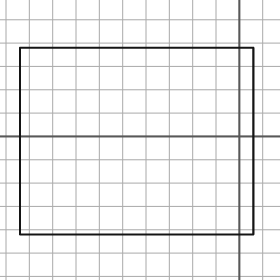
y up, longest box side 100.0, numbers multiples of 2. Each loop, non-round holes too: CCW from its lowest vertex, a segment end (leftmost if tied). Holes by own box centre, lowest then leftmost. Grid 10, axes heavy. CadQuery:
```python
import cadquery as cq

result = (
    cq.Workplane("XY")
    .moveTo(-94.0, -42.0)
    .lineTo(6.0, -42.0)
    .lineTo(6.0, 38.0)
    .lineTo(-94.0, 38.0)
    .close()
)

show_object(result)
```